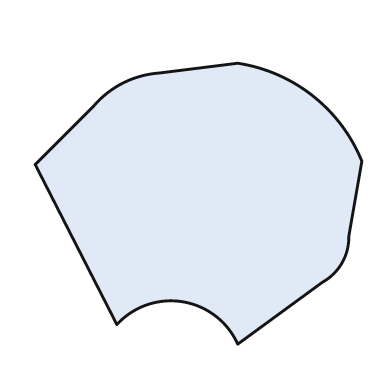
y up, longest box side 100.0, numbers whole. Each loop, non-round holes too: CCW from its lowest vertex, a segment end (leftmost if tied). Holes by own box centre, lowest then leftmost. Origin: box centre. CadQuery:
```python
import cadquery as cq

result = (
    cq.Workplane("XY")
    .moveTo(12.0, -43.0)
    .lineTo(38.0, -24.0)
    .threePointArc((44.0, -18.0), (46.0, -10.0))
    .lineTo(50.0, 13.0)
    .threePointArc((35.0, 33.0), (12.0, 43.0))
    .lineTo(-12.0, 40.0)
    .threePointArc((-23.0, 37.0), (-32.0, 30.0))
    .lineTo(-50.0, 12.0)
    .lineTo(-25.0, -37.0)
    .threePointArc((-5.0, -30.0), (12.0, -43.0))
    .close()
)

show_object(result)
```